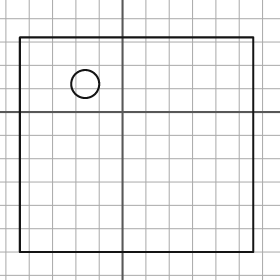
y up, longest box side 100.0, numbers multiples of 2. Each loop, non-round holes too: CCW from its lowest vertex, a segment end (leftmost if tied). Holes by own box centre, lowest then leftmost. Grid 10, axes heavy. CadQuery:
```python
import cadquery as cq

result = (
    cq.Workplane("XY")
    .moveTo(-44.0, -60.0)
    .lineTo(56.0, -60.0)
    .lineTo(56.0, 32.0)
    .lineTo(-44.0, 32.0)
    .close()
    .moveTo(-16.0, 12.0)
    .circle(6.0)
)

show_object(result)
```